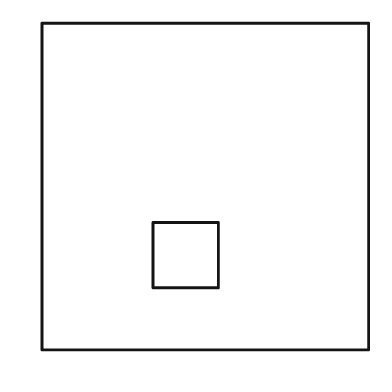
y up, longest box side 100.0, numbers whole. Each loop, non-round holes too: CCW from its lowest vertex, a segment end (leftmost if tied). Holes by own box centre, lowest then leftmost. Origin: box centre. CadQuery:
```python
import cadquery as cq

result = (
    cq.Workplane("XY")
    .moveTo(-50.0, -50.0)
    .lineTo(50.0, -50.0)
    .lineTo(50.0, 50.0)
    .lineTo(-50.0, 50.0)
    .close()
    .moveTo(-16.0, -31.0)
    .lineTo(4.0, -31.0)
    .lineTo(4.0, -11.0)
    .lineTo(-16.0, -11.0)
    .close()
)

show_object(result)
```